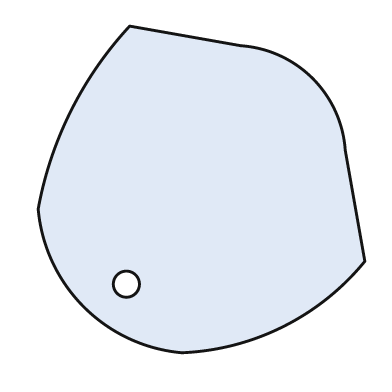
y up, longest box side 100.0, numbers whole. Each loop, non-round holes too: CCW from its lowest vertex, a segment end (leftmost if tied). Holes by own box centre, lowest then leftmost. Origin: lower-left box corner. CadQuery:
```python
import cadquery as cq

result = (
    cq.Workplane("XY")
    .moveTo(44.0, 0.0)
    .threePointArc((75.0, 8.0), (100.0, 28.0))
    .lineTo(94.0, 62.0)
    .threePointArc((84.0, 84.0), (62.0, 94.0))
    .lineTo(28.0, 100.0)
    .threePointArc((10.0, 74.0), (0.0, 44.0))
    .threePointArc((14.0, 14.0), (44.0, 0.0))
    .close()
    .moveTo(27.0, 21.0)
    .circle(4.0)
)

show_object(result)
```